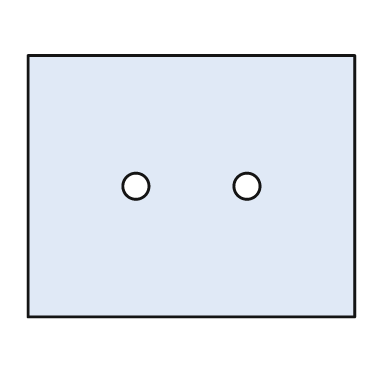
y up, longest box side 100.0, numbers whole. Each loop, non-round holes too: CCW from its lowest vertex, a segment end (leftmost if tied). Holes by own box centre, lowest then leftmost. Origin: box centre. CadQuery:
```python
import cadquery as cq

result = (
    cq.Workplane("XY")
    .moveTo(-50.0, -40.0)
    .lineTo(50.0, -40.0)
    .lineTo(50.0, 40.0)
    .lineTo(-50.0, 40.0)
    .close()
    .moveTo(-17.0, 0.0)
    .circle(4.0)
    .moveTo(17.0, 0.0)
    .circle(4.0)
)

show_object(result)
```